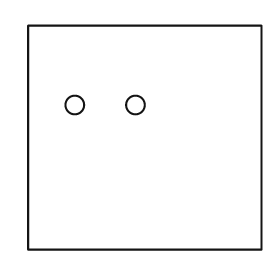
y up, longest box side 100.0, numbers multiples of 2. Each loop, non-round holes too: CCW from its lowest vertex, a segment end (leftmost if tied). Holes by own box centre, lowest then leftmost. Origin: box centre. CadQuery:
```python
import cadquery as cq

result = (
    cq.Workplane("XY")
    .moveTo(-50.0, -48.0)
    .lineTo(50.0, -48.0)
    .lineTo(50.0, 48.0)
    .lineTo(-50.0, 48.0)
    .close()
    .moveTo(-30.0, 14.0)
    .circle(4.0)
    .moveTo(-4.0, 14.0)
    .circle(4.0)
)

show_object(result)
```